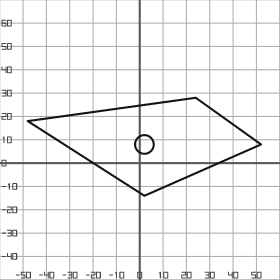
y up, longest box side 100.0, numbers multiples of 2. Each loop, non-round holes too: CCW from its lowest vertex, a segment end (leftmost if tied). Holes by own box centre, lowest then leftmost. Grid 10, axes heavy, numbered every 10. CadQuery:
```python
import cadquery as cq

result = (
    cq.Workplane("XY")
    .moveTo(2.0, -14.0)
    .lineTo(52.0, 8.0)
    .lineTo(24.0, 28.0)
    .lineTo(-48.0, 18.0)
    .close()
    .moveTo(2.0, 8.0)
    .circle(4.0)
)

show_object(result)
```